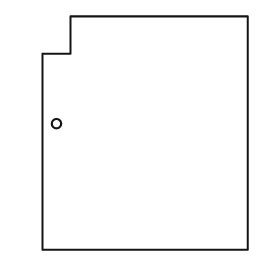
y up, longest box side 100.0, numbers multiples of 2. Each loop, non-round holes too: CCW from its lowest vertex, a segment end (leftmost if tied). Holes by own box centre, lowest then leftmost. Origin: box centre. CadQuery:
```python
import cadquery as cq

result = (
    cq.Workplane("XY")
    .moveTo(-44.0, -50.0)
    .lineTo(44.0, -50.0)
    .lineTo(44.0, 50.0)
    .lineTo(-32.0, 50.0)
    .lineTo(-32.0, 34.0)
    .lineTo(-44.0, 34.0)
    .close()
    .moveTo(-38.0, 4.0)
    .circle(2.0)
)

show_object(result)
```